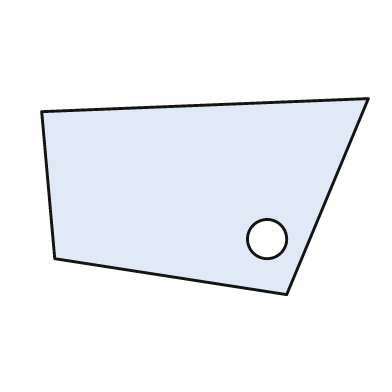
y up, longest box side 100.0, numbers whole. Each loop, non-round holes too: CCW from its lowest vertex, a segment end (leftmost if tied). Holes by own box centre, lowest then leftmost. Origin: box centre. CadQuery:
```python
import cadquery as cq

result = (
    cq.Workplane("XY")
    .moveTo(25.0, -30.0)
    .lineTo(50.0, 30.0)
    .lineTo(-50.0, 26.0)
    .lineTo(-46.0, -19.0)
    .close()
    .moveTo(19.0, -13.0)
    .circle(6.0)
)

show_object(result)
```